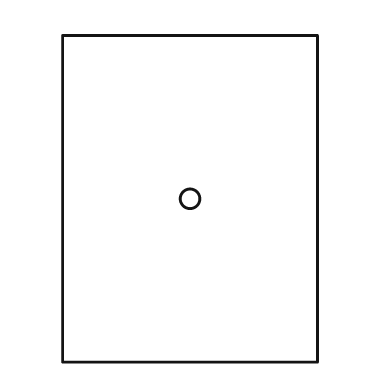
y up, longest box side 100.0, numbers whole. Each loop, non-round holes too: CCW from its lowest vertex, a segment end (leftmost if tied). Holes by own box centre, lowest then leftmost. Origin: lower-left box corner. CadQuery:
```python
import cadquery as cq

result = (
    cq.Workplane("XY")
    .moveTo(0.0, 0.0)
    .lineTo(78.0, 0.0)
    .lineTo(78.0, 100.0)
    .lineTo(0.0, 100.0)
    .close()
    .moveTo(39.0, 50.0)
    .circle(3.0)
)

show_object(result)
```